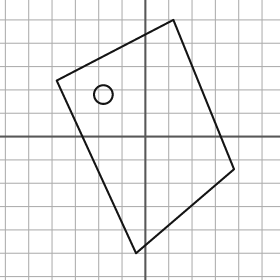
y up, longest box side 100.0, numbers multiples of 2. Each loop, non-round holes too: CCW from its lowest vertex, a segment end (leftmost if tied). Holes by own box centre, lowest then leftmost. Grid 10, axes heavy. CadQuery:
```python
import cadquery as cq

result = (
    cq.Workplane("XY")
    .moveTo(-4.0, -50.0)
    .lineTo(38.0, -14.0)
    .lineTo(12.0, 50.0)
    .lineTo(-38.0, 24.0)
    .close()
    .moveTo(-18.0, 18.0)
    .circle(4.0)
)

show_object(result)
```